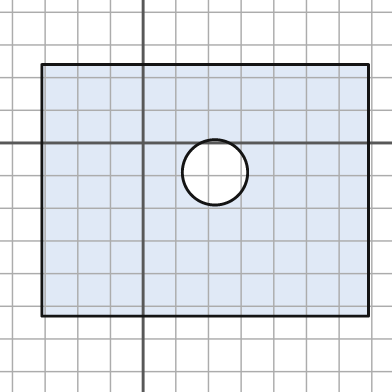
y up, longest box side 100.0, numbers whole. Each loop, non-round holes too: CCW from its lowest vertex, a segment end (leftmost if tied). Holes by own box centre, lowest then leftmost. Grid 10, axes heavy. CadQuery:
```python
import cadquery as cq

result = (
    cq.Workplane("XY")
    .moveTo(-31.0, -53.0)
    .lineTo(69.0, -53.0)
    .lineTo(69.0, 24.0)
    .lineTo(-31.0, 24.0)
    .close()
    .moveTo(22.0, -9.0)
    .circle(10.0)
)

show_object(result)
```